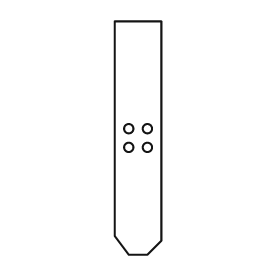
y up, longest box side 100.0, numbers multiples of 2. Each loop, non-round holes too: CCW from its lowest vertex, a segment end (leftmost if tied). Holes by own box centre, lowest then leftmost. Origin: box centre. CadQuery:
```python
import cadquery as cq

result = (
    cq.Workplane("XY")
    .moveTo(-4.0, -50.0)
    .lineTo(4.0, -50.0)
    .lineTo(10.0, -44.0)
    .lineTo(10.0, 50.0)
    .lineTo(-10.0, 50.0)
    .lineTo(-10.0, -42.0)
    .close()
    .moveTo(-4.0, -4.0)
    .circle(2.0)
    .moveTo(4.0, -4.0)
    .circle(2.0)
    .moveTo(-4.0, 4.0)
    .circle(2.0)
    .moveTo(4.0, 4.0)
    .circle(2.0)
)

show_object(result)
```